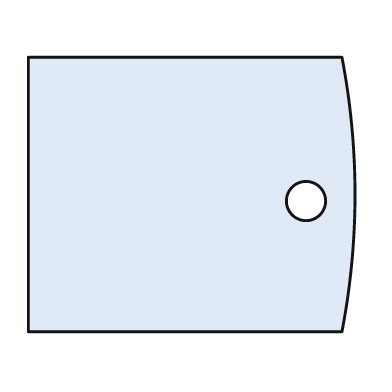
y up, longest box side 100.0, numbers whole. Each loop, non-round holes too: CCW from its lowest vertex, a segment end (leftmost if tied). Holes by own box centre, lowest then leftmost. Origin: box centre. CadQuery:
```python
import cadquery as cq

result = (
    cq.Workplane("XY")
    .moveTo(-50.0, -42.0)
    .lineTo(46.0, -42.0)
    .threePointArc((50.0, 0.0), (46.0, 42.0))
    .lineTo(-50.0, 42.0)
    .close()
    .moveTo(35.0, -2.0)
    .circle(6.0)
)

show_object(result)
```